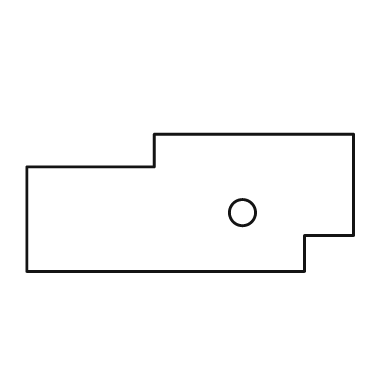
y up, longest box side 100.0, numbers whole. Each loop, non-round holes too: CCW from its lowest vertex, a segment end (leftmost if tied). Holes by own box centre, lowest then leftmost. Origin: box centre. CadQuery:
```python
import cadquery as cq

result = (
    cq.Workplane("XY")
    .moveTo(-50.0, -21.0)
    .lineTo(35.0, -21.0)
    .lineTo(35.0, -10.0)
    .lineTo(50.0, -10.0)
    .lineTo(50.0, 21.0)
    .lineTo(-11.0, 21.0)
    .lineTo(-11.0, 11.0)
    .lineTo(-50.0, 11.0)
    .close()
    .moveTo(16.0, -3.0)
    .circle(4.0)
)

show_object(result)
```